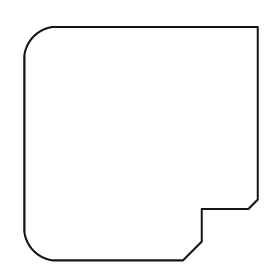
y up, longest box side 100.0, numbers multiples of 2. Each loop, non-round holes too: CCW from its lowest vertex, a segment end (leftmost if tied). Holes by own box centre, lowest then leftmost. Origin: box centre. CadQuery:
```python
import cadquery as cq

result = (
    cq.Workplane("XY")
    .moveTo(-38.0, -50.0)
    .lineTo(18.0, -50.0)
    .lineTo(26.0, -42.0)
    .lineTo(26.0, -28.0)
    .lineTo(46.0, -28.0)
    .lineTo(50.0, -24.0)
    .lineTo(50.0, 50.0)
    .lineTo(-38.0, 50.0)
    .threePointArc((-46.0, 46.0), (-50.0, 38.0))
    .lineTo(-50.0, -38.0)
    .threePointArc((-46.0, -46.0), (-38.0, -50.0))
    .close()
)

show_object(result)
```